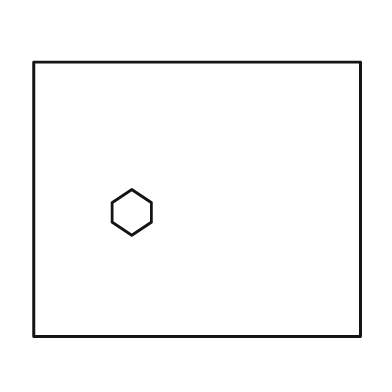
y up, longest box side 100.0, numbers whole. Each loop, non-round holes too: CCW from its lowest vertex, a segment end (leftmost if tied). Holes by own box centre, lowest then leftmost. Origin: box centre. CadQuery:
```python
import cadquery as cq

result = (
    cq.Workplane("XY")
    .moveTo(-50.0, -42.0)
    .lineTo(50.0, -42.0)
    .lineTo(50.0, 42.0)
    .lineTo(-50.0, 42.0)
    .close()
    .moveTo(-20.0, -11.0)
    .lineTo(-14.0, -7.0)
    .lineTo(-14.0, -1.0)
    .lineTo(-20.0, 3.0)
    .lineTo(-26.0, -1.0)
    .lineTo(-26.0, -7.0)
    .close()
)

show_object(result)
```